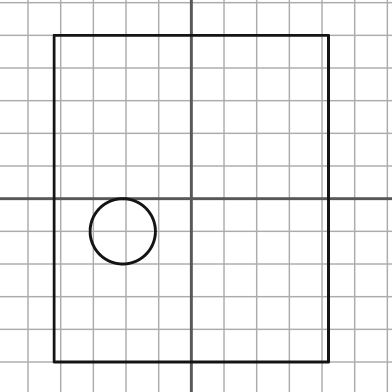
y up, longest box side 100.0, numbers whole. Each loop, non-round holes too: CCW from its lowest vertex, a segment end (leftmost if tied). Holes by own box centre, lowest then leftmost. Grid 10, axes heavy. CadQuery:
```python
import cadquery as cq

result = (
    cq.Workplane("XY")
    .moveTo(-42.0, -50.0)
    .lineTo(42.0, -50.0)
    .lineTo(42.0, 50.0)
    .lineTo(-42.0, 50.0)
    .close()
    .moveTo(-21.0, -10.0)
    .circle(10.0)
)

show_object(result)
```